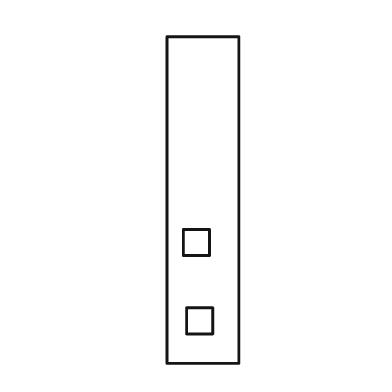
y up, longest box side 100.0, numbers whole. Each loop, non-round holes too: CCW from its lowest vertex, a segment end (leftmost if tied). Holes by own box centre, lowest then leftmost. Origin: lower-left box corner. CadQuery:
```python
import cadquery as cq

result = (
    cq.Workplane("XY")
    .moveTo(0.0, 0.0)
    .lineTo(22.0, 0.0)
    .lineTo(22.0, 100.0)
    .lineTo(0.0, 100.0)
    .close()
    .moveTo(6.0, 9.0)
    .lineTo(14.0, 9.0)
    .lineTo(14.0, 17.0)
    .lineTo(6.0, 17.0)
    .close()
    .moveTo(5.0, 33.0)
    .lineTo(13.0, 33.0)
    .lineTo(13.0, 41.0)
    .lineTo(5.0, 41.0)
    .close()
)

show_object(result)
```